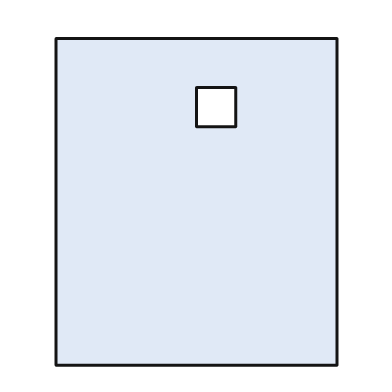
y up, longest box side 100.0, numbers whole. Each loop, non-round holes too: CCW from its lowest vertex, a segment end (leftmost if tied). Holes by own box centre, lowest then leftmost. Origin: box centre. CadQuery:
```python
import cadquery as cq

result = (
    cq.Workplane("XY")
    .moveTo(-43.0, -50.0)
    .lineTo(43.0, -50.0)
    .lineTo(43.0, 50.0)
    .lineTo(-43.0, 50.0)
    .close()
    .moveTo(0.0, 23.0)
    .lineTo(12.0, 23.0)
    .lineTo(12.0, 35.0)
    .lineTo(0.0, 35.0)
    .close()
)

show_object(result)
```